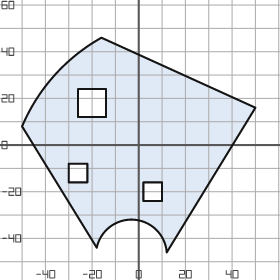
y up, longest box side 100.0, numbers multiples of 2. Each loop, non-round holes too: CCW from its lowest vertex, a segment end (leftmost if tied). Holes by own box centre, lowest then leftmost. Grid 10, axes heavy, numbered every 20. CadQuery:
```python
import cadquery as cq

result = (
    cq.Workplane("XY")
    .moveTo(12.0, -46.0)
    .lineTo(50.0, 16.0)
    .lineTo(-16.0, 46.0)
    .threePointArc((-36.0, 30.0), (-50.0, 8.0))
    .lineTo(-18.0, -44.0)
    .threePointArc((-2.0, -32.0), (12.0, -46.0))
    .close()
    .moveTo(2.0, -24.0)
    .lineTo(10.0, -24.0)
    .lineTo(10.0, -16.0)
    .lineTo(2.0, -16.0)
    .close()
    .moveTo(-30.0, -16.0)
    .lineTo(-22.0, -16.0)
    .lineTo(-22.0, -8.0)
    .lineTo(-30.0, -8.0)
    .close()
    .moveTo(-26.0, 12.0)
    .lineTo(-14.0, 12.0)
    .lineTo(-14.0, 24.0)
    .lineTo(-26.0, 24.0)
    .close()
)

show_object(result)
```